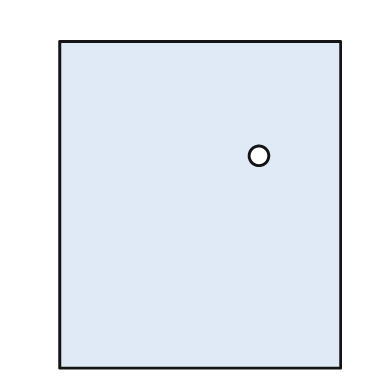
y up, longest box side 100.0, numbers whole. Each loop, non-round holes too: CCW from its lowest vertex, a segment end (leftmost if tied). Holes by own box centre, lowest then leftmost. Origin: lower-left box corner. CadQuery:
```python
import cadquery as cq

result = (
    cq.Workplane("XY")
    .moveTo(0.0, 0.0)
    .lineTo(86.0, 0.0)
    .lineTo(86.0, 100.0)
    .lineTo(0.0, 100.0)
    .close()
    .moveTo(61.0, 65.0)
    .circle(3.0)
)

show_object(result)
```